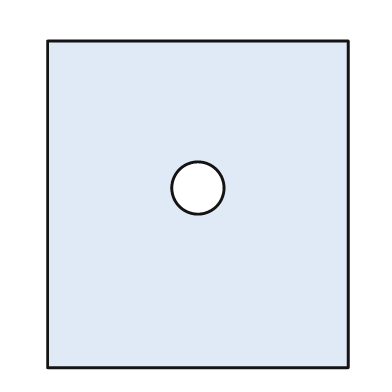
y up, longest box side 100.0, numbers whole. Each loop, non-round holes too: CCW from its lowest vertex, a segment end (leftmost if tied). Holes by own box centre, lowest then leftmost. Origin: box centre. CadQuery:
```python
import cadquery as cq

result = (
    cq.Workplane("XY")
    .moveTo(-46.0, -50.0)
    .lineTo(46.0, -50.0)
    .lineTo(46.0, 50.0)
    .lineTo(-46.0, 50.0)
    .close()
    .moveTo(0.0, 5.0)
    .circle(8.0)
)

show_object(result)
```